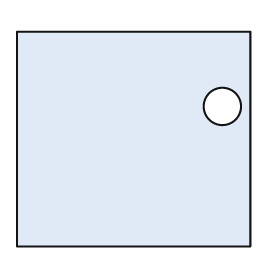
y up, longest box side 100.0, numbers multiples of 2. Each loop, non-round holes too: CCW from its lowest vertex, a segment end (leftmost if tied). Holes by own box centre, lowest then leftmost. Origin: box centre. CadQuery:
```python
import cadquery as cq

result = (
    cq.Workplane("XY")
    .moveTo(-50.0, -46.0)
    .lineTo(50.0, -46.0)
    .lineTo(50.0, 46.0)
    .lineTo(-50.0, 46.0)
    .close()
    .moveTo(38.0, 14.0)
    .circle(8.0)
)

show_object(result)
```